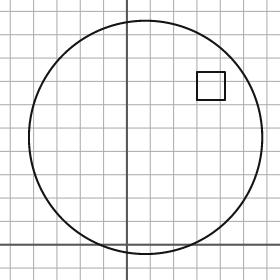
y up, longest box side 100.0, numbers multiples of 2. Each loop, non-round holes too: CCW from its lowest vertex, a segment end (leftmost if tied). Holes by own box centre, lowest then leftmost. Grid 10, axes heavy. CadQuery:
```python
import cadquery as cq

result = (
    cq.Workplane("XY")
    .moveTo(8.0, 46.0)
    .circle(50.0)
    .moveTo(30.0, 62.0)
    .lineTo(42.0, 62.0)
    .lineTo(42.0, 74.0)
    .lineTo(30.0, 74.0)
    .close()
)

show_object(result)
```